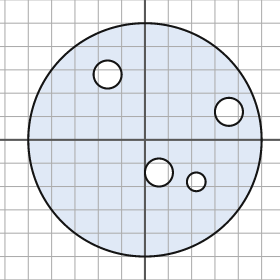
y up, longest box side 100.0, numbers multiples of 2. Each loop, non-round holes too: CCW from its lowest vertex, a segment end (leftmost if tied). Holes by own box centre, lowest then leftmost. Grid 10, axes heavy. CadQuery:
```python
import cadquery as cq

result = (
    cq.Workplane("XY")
    .moveTo(0.0, 0.0)
    .circle(50.0)
    .moveTo(22.0, -18.0)
    .circle(4.0)
    .moveTo(6.0, -14.0)
    .circle(6.0)
    .moveTo(36.0, 12.0)
    .circle(6.0)
    .moveTo(-16.0, 28.0)
    .circle(6.0)
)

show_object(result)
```